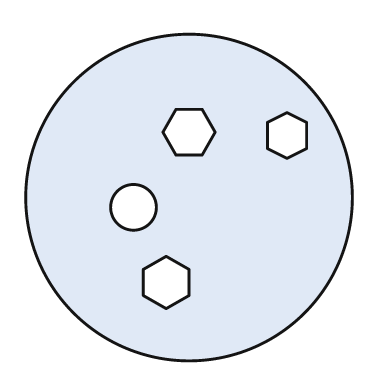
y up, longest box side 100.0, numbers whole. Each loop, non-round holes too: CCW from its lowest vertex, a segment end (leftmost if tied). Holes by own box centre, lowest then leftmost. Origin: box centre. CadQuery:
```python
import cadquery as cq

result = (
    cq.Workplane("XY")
    .moveTo(0.0, 0.0)
    .circle(50.0)
    .moveTo(-7.0, -34.0)
    .lineTo(0.0, -30.0)
    .lineTo(0.0, -22.0)
    .lineTo(-7.0, -18.0)
    .lineTo(-14.0, -22.0)
    .lineTo(-14.0, -30.0)
    .close()
    .moveTo(-17.0, -3.0)
    .circle(7.0)
    .moveTo(30.0, 12.0)
    .lineTo(36.0, 15.0)
    .lineTo(36.0, 23.0)
    .lineTo(30.0, 26.0)
    .lineTo(24.0, 23.0)
    .lineTo(24.0, 15.0)
    .close()
    .moveTo(-4.0, 13.0)
    .lineTo(4.0, 13.0)
    .lineTo(8.0, 20.0)
    .lineTo(4.0, 27.0)
    .lineTo(-4.0, 27.0)
    .lineTo(-8.0, 20.0)
    .close()
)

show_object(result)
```